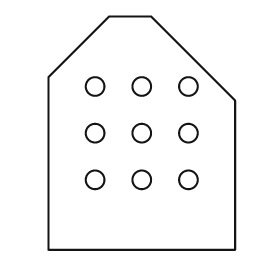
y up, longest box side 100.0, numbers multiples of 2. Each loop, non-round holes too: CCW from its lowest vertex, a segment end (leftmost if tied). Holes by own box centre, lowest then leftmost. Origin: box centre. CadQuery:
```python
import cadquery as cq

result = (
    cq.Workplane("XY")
    .moveTo(-40.0, -50.0)
    .lineTo(40.0, -50.0)
    .lineTo(40.0, 14.0)
    .lineTo(4.0, 50.0)
    .lineTo(-14.0, 50.0)
    .lineTo(-40.0, 24.0)
    .close()
    .moveTo(-20.0, -20.0)
    .circle(4.0)
    .moveTo(0.0, -20.0)
    .circle(4.0)
    .moveTo(20.0, -20.0)
    .circle(4.0)
    .moveTo(-20.0, 0.0)
    .circle(4.0)
    .moveTo(0.0, 0.0)
    .circle(4.0)
    .moveTo(20.0, 0.0)
    .circle(4.0)
    .moveTo(-20.0, 20.0)
    .circle(4.0)
    .moveTo(0.0, 20.0)
    .circle(4.0)
    .moveTo(20.0, 20.0)
    .circle(4.0)
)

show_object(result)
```